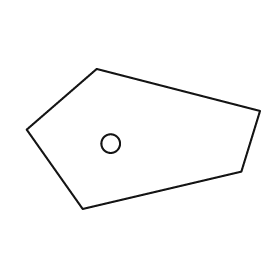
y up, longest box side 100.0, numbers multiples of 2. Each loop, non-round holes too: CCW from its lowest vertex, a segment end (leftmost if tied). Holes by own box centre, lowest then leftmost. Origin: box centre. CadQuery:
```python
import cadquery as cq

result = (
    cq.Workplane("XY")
    .moveTo(-26.0, -30.0)
    .lineTo(42.0, -14.0)
    .lineTo(50.0, 12.0)
    .lineTo(-20.0, 30.0)
    .lineTo(-50.0, 4.0)
    .close()
    .moveTo(-14.0, -2.0)
    .circle(4.0)
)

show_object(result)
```